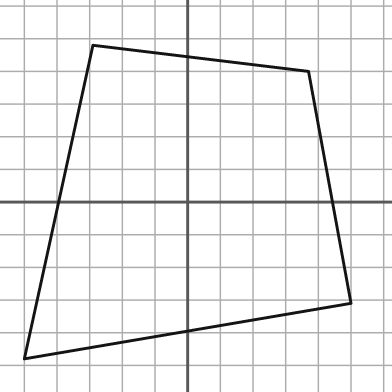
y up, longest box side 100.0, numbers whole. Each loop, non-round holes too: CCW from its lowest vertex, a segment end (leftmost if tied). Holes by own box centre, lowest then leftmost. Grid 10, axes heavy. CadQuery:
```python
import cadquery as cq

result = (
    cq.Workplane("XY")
    .moveTo(-50.0, -48.0)
    .lineTo(50.0, -31.0)
    .lineTo(37.0, 40.0)
    .lineTo(-29.0, 48.0)
    .close()
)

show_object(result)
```